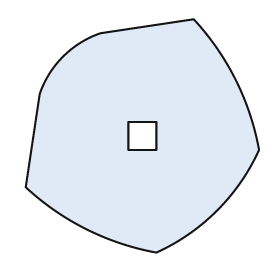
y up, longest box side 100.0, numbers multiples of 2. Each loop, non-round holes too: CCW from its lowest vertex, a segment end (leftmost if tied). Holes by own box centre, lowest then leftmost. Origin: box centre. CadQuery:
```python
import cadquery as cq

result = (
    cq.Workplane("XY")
    .moveTo(6.0, -50.0)
    .threePointArc((32.0, -32.0), (50.0, -6.0))
    .threePointArc((40.0, 24.0), (22.0, 50.0))
    .lineTo(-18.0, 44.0)
    .threePointArc((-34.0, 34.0), (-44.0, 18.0))
    .lineTo(-50.0, -22.0)
    .threePointArc((-24.0, -40.0), (6.0, -50.0))
    .close()
    .moveTo(-6.0, -6.0)
    .lineTo(6.0, -6.0)
    .lineTo(6.0, 6.0)
    .lineTo(-6.0, 6.0)
    .close()
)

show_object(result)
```